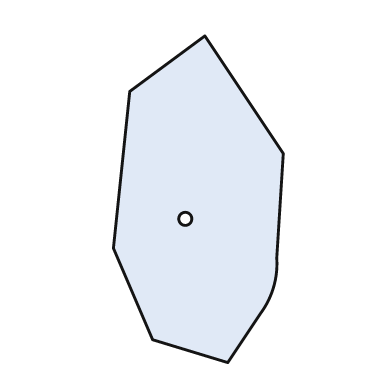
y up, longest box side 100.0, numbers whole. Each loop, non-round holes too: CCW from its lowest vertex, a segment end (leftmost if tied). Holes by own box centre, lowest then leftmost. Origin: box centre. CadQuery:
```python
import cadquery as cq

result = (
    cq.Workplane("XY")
    .moveTo(9.0, -50.0)
    .lineTo(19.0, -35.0)
    .threePointArc((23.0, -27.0), (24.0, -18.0))
    .lineTo(26.0, 14.0)
    .lineTo(2.0, 50.0)
    .lineTo(-21.0, 33.0)
    .lineTo(-26.0, -15.0)
    .lineTo(-14.0, -43.0)
    .close()
    .moveTo(-4.0, -6.0)
    .circle(2.0)
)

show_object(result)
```